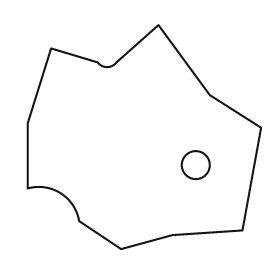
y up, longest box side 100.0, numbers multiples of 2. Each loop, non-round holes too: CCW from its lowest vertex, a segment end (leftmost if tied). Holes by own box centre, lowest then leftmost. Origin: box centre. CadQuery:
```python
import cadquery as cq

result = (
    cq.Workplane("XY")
    .moveTo(-10.0, -48.0)
    .lineTo(12.0, -42.0)
    .lineTo(42.0, -40.0)
    .lineTo(50.0, 4.0)
    .lineTo(28.0, 18.0)
    .lineTo(6.0, 48.0)
    .lineTo(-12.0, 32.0)
    .threePointArc((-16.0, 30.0), (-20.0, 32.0))
    .lineTo(-40.0, 38.0)
    .lineTo(-50.0, 6.0)
    .lineTo(-50.0, -22.0)
    .threePointArc((-36.0, -24.0), (-28.0, -36.0))
    .close()
    .moveTo(22.0, -12.0)
    .circle(6.0)
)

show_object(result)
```